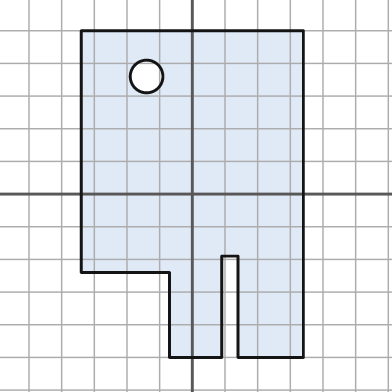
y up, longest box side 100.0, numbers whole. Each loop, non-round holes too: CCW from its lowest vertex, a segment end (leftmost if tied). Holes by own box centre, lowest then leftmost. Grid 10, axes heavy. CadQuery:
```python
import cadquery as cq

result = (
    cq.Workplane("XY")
    .moveTo(-7.0, -50.0)
    .lineTo(9.0, -50.0)
    .lineTo(9.0, -19.0)
    .lineTo(14.0, -19.0)
    .lineTo(14.0, -50.0)
    .lineTo(34.0, -50.0)
    .lineTo(34.0, 50.0)
    .lineTo(-34.0, 50.0)
    .lineTo(-34.0, -24.0)
    .lineTo(-7.0, -24.0)
    .close()
    .moveTo(-14.0, 36.0)
    .circle(5.0)
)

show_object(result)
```